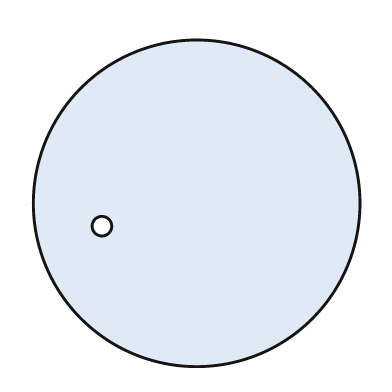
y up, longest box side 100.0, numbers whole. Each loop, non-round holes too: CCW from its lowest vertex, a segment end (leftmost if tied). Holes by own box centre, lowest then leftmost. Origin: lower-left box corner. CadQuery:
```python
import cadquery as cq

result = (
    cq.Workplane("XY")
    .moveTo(50.0, 50.0)
    .circle(50.0)
    .moveTo(21.0, 43.0)
    .circle(3.0)
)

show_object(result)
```